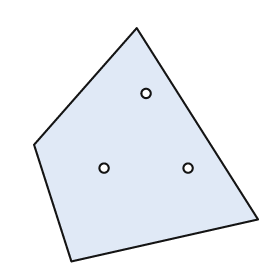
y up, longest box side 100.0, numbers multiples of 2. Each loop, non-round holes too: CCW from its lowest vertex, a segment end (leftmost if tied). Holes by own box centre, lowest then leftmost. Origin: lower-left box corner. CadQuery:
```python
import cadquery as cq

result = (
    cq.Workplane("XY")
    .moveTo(16.0, 0.0)
    .lineTo(96.0, 18.0)
    .lineTo(44.0, 100.0)
    .lineTo(0.0, 50.0)
    .close()
    .moveTo(30.0, 40.0)
    .circle(2.0)
    .moveTo(66.0, 40.0)
    .circle(2.0)
    .moveTo(48.0, 72.0)
    .circle(2.0)
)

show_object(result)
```